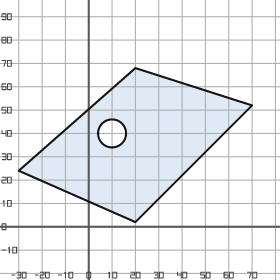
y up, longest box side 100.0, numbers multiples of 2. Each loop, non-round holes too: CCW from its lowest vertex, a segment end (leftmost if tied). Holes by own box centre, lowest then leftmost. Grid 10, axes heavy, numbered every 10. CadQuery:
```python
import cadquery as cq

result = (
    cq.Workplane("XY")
    .moveTo(20.0, 2.0)
    .lineTo(70.0, 52.0)
    .lineTo(20.0, 68.0)
    .lineTo(-30.0, 24.0)
    .close()
    .moveTo(10.0, 40.0)
    .circle(6.0)
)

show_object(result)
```